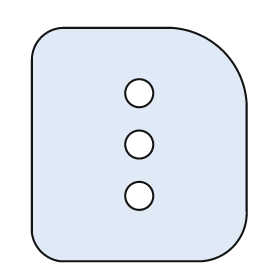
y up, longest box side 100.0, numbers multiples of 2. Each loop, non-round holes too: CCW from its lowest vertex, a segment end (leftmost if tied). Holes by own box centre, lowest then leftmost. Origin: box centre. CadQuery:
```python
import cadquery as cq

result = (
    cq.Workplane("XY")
    .moveTo(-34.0, -50.0)
    .lineTo(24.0, -50.0)
    .threePointArc((40.0, -44.0), (46.0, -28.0))
    .lineTo(46.0, 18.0)
    .threePointArc((36.0, 40.0), (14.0, 50.0))
    .lineTo(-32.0, 50.0)
    .threePointArc((-42.0, 46.0), (-46.0, 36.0))
    .lineTo(-46.0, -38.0)
    .threePointArc((-42.0, -46.0), (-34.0, -50.0))
    .close()
    .moveTo(0.0, -22.0)
    .circle(6.0)
    .moveTo(0.0, 0.0)
    .circle(6.0)
    .moveTo(0.0, 22.0)
    .circle(6.0)
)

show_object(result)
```